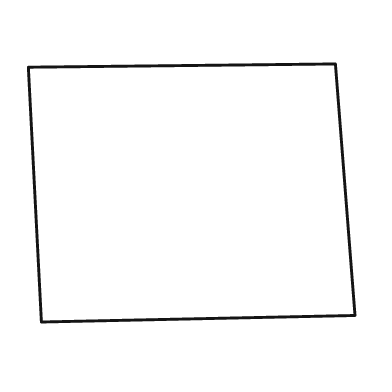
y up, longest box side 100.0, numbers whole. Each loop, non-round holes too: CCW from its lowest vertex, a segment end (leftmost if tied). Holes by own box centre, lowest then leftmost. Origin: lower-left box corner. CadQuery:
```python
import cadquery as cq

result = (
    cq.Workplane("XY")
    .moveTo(4.0, 0.0)
    .lineTo(100.0, 2.0)
    .lineTo(94.0, 79.0)
    .lineTo(0.0, 78.0)
    .close()
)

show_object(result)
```